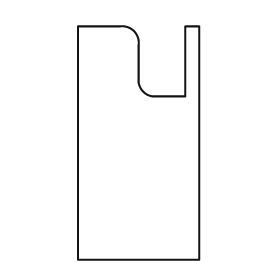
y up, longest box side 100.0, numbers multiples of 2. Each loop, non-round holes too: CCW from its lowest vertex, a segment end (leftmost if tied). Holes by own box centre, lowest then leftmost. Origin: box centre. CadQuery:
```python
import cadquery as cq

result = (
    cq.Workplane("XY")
    .moveTo(-26.0, -50.0)
    .lineTo(26.0, -50.0)
    .lineTo(26.0, 50.0)
    .lineTo(20.0, 50.0)
    .lineTo(20.0, 20.0)
    .lineTo(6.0, 20.0)
    .threePointArc((2.0, 22.0), (0.0, 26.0))
    .lineTo(0.0, 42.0)
    .threePointArc((-2.0, 48.0), (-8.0, 50.0))
    .lineTo(-26.0, 50.0)
    .close()
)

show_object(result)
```